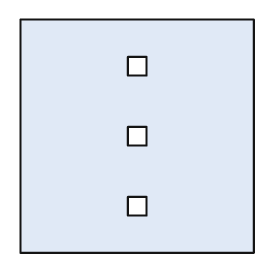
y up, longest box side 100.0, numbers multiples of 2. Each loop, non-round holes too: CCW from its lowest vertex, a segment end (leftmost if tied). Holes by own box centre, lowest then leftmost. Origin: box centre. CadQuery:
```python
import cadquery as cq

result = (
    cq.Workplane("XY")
    .moveTo(-50.0, -50.0)
    .lineTo(50.0, -50.0)
    .lineTo(50.0, 50.0)
    .lineTo(-50.0, 50.0)
    .close()
    .moveTo(-4.0, -34.0)
    .lineTo(4.0, -34.0)
    .lineTo(4.0, -26.0)
    .lineTo(-4.0, -26.0)
    .close()
    .moveTo(-4.0, -4.0)
    .lineTo(4.0, -4.0)
    .lineTo(4.0, 4.0)
    .lineTo(-4.0, 4.0)
    .close()
    .moveTo(-4.0, 26.0)
    .lineTo(4.0, 26.0)
    .lineTo(4.0, 34.0)
    .lineTo(-4.0, 34.0)
    .close()
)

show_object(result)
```